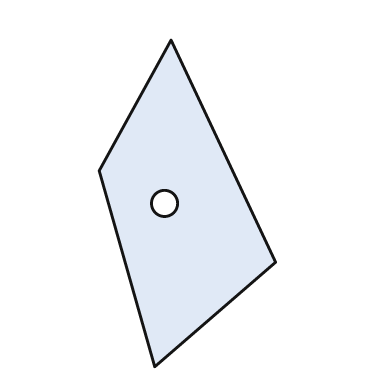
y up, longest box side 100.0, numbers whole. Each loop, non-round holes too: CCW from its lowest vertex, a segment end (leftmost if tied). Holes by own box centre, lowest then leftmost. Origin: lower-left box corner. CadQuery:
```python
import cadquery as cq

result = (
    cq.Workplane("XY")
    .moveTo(17.0, 0.0)
    .lineTo(54.0, 32.0)
    .lineTo(22.0, 100.0)
    .lineTo(0.0, 60.0)
    .close()
    .moveTo(20.0, 50.0)
    .circle(4.0)
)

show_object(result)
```